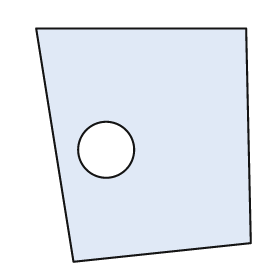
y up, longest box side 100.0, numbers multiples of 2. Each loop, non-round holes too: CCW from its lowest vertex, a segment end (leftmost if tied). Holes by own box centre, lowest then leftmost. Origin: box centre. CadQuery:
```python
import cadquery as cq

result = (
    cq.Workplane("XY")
    .moveTo(-30.0, -50.0)
    .lineTo(46.0, -42.0)
    .lineTo(44.0, 50.0)
    .lineTo(-46.0, 50.0)
    .close()
    .moveTo(-16.0, -2.0)
    .circle(12.0)
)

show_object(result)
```